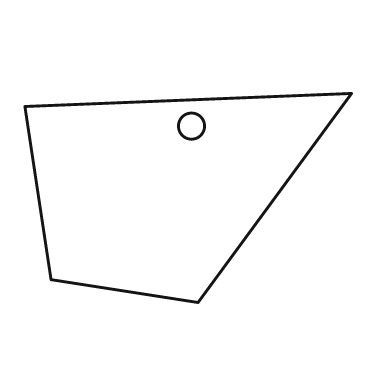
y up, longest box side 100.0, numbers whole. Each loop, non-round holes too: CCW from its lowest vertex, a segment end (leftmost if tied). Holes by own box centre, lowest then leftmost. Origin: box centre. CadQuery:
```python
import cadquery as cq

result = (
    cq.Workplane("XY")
    .moveTo(3.0, -32.0)
    .lineTo(50.0, 32.0)
    .lineTo(-50.0, 28.0)
    .lineTo(-42.0, -25.0)
    .close()
    .moveTo(1.0, 22.0)
    .circle(4.0)
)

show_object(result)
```